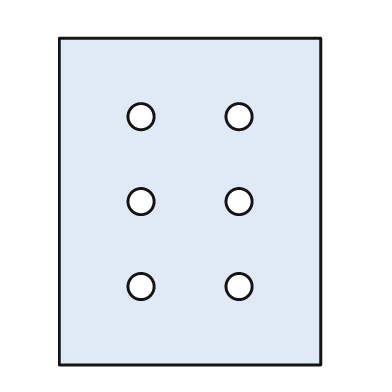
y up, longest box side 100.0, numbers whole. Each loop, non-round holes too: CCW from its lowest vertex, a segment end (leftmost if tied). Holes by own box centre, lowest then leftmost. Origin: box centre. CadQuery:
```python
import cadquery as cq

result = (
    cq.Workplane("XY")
    .moveTo(-40.0, -50.0)
    .lineTo(40.0, -50.0)
    .lineTo(40.0, 50.0)
    .lineTo(-40.0, 50.0)
    .close()
    .moveTo(-15.0, -26.0)
    .circle(4.0)
    .moveTo(15.0, -26.0)
    .circle(4.0)
    .moveTo(-15.0, 0.0)
    .circle(4.0)
    .moveTo(15.0, 0.0)
    .circle(4.0)
    .moveTo(-15.0, 26.0)
    .circle(4.0)
    .moveTo(15.0, 26.0)
    .circle(4.0)
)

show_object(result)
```